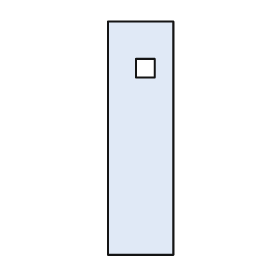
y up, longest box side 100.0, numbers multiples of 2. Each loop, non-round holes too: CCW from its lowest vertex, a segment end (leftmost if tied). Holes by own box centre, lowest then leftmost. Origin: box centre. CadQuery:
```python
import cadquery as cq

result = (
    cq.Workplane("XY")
    .moveTo(-14.0, -50.0)
    .lineTo(14.0, -50.0)
    .lineTo(14.0, 50.0)
    .lineTo(-14.0, 50.0)
    .close()
    .moveTo(-2.0, 26.0)
    .lineTo(6.0, 26.0)
    .lineTo(6.0, 34.0)
    .lineTo(-2.0, 34.0)
    .close()
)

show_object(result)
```